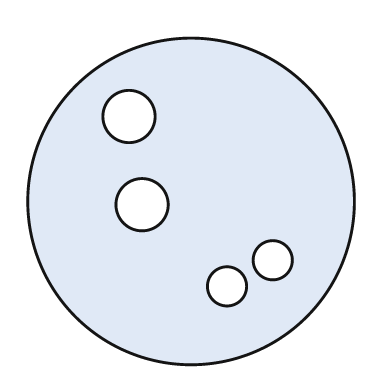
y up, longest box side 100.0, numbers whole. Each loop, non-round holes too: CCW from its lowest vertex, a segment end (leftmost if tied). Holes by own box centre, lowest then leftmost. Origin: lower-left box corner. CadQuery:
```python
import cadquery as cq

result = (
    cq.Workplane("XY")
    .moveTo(50.0, 50.0)
    .circle(50.0)
    .moveTo(61.0, 24.0)
    .circle(6.0)
    .moveTo(75.0, 32.0)
    .circle(6.0)
    .moveTo(35.0, 49.0)
    .circle(8.0)
    .moveTo(31.0, 76.0)
    .circle(8.0)
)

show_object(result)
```